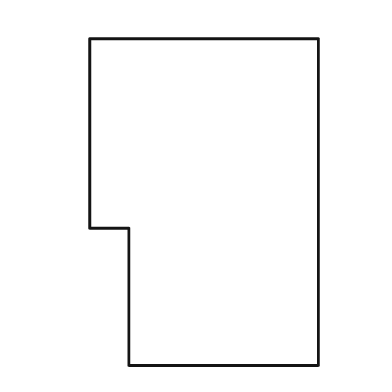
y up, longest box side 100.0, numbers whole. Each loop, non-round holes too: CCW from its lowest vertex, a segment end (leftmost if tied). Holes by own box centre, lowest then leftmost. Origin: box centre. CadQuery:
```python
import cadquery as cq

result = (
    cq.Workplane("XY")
    .moveTo(-23.0, -50.0)
    .lineTo(35.0, -50.0)
    .lineTo(35.0, 50.0)
    .lineTo(-35.0, 50.0)
    .lineTo(-35.0, -8.0)
    .lineTo(-23.0, -8.0)
    .close()
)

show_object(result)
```